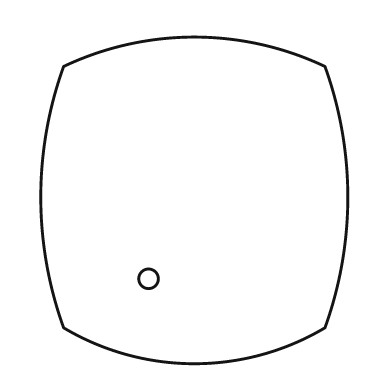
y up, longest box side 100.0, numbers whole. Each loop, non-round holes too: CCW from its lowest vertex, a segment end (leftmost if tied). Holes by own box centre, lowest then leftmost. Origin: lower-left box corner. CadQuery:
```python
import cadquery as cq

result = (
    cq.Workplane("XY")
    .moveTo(7.0, 11.0)
    .threePointArc((47.0, 0.0), (87.0, 11.0))
    .threePointArc((94.0, 51.0), (87.0, 91.0))
    .threePointArc((47.0, 100.0), (7.0, 91.0))
    .threePointArc((0.0, 51.0), (7.0, 11.0))
    .close()
    .moveTo(33.0, 26.0)
    .circle(3.0)
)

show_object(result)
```